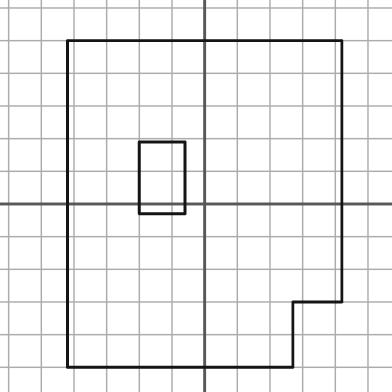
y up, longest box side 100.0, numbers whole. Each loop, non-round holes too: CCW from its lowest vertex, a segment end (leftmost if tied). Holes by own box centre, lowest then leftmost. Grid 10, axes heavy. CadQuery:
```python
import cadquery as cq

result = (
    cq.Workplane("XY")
    .moveTo(-42.0, -50.0)
    .lineTo(27.0, -50.0)
    .lineTo(27.0, -30.0)
    .lineTo(42.0, -30.0)
    .lineTo(42.0, 50.0)
    .lineTo(-42.0, 50.0)
    .close()
    .moveTo(-20.0, -3.0)
    .lineTo(-6.0, -3.0)
    .lineTo(-6.0, 19.0)
    .lineTo(-20.0, 19.0)
    .close()
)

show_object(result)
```